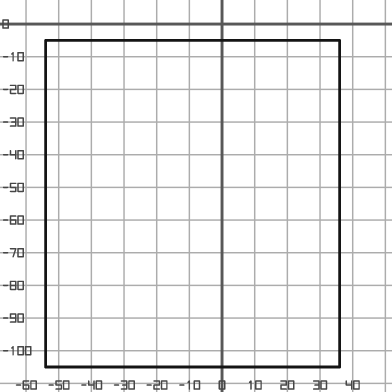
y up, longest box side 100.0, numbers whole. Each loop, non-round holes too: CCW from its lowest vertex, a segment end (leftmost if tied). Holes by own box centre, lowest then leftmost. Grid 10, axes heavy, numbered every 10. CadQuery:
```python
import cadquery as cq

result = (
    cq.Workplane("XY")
    .moveTo(-54.0, -105.0)
    .lineTo(36.0, -105.0)
    .lineTo(36.0, -5.0)
    .lineTo(-54.0, -5.0)
    .close()
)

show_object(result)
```